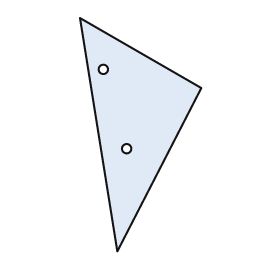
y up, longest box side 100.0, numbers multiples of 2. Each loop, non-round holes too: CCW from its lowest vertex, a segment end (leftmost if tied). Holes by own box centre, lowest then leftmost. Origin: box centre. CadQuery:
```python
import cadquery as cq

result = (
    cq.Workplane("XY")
    .moveTo(-10.0, -50.0)
    .lineTo(26.0, 20.0)
    .lineTo(-26.0, 50.0)
    .close()
    .moveTo(-6.0, -6.0)
    .circle(2.0)
    .moveTo(-16.0, 28.0)
    .circle(2.0)
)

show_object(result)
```